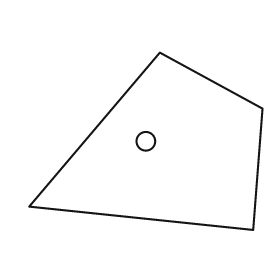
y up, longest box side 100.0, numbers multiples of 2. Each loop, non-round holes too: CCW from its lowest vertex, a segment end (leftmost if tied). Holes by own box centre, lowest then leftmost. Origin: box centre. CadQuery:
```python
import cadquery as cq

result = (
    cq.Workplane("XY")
    .moveTo(46.0, -38.0)
    .lineTo(50.0, 14.0)
    .lineTo(6.0, 38.0)
    .lineTo(-50.0, -28.0)
    .close()
    .moveTo(0.0, 0.0)
    .circle(4.0)
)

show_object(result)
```